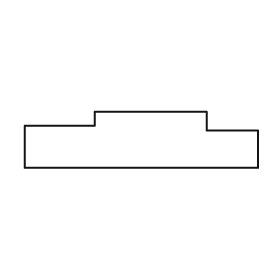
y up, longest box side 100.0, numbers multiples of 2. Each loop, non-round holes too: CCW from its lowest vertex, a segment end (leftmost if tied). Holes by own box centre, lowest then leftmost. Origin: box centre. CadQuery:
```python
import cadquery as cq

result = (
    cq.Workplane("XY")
    .moveTo(-50.0, -12.0)
    .lineTo(50.0, -12.0)
    .lineTo(50.0, 4.0)
    .lineTo(28.0, 4.0)
    .lineTo(28.0, 12.0)
    .lineTo(-20.0, 12.0)
    .lineTo(-20.0, 6.0)
    .lineTo(-50.0, 6.0)
    .close()
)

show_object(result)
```